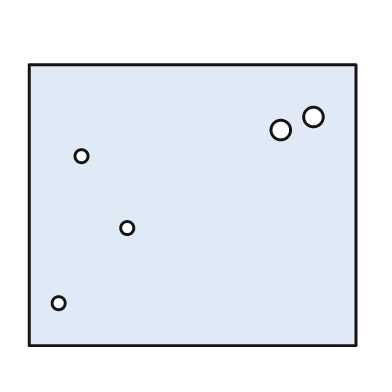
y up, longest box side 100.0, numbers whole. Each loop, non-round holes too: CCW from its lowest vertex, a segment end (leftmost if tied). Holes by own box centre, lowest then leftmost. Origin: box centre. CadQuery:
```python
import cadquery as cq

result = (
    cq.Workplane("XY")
    .moveTo(-50.0, -43.0)
    .lineTo(50.0, -43.0)
    .lineTo(50.0, 43.0)
    .lineTo(-50.0, 43.0)
    .close()
    .moveTo(-41.0, -30.0)
    .circle(2.0)
    .moveTo(-20.0, -7.0)
    .circle(2.0)
    .moveTo(-34.0, 15.0)
    .circle(2.0)
    .moveTo(27.0, 23.0)
    .circle(3.0)
    .moveTo(37.0, 27.0)
    .circle(3.0)
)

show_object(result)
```